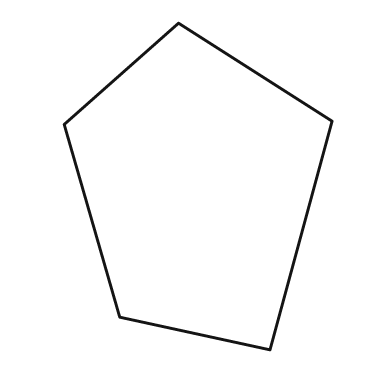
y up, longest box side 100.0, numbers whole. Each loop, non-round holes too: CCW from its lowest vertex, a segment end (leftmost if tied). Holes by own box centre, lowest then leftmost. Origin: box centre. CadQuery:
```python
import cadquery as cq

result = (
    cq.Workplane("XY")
    .moveTo(22.0, -50.0)
    .lineTo(41.0, 20.0)
    .lineTo(-6.0, 50.0)
    .lineTo(-41.0, 19.0)
    .lineTo(-24.0, -40.0)
    .close()
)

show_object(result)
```